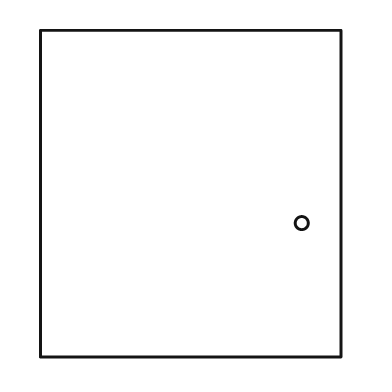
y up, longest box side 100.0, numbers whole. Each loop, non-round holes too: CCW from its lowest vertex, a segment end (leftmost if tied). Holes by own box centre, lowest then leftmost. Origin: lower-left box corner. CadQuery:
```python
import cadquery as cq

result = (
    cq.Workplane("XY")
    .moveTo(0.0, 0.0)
    .lineTo(92.0, 0.0)
    .lineTo(92.0, 100.0)
    .lineTo(0.0, 100.0)
    .close()
    .moveTo(80.0, 41.0)
    .circle(2.0)
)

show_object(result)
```